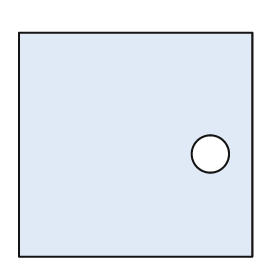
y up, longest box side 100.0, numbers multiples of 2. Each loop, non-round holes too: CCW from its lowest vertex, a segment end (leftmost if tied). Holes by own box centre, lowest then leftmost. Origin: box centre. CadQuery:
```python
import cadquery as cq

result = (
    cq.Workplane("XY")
    .moveTo(-50.0, -48.0)
    .lineTo(50.0, -48.0)
    .lineTo(50.0, 48.0)
    .lineTo(-50.0, 48.0)
    .close()
    .moveTo(32.0, -4.0)
    .circle(8.0)
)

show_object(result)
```